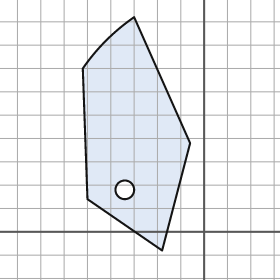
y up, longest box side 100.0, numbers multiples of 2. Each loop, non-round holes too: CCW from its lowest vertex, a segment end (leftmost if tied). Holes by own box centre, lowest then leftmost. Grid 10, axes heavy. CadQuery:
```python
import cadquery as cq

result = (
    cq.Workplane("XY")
    .moveTo(-18.0, -8.0)
    .lineTo(-6.0, 38.0)
    .lineTo(-30.0, 92.0)
    .threePointArc((-42.0, 82.0), (-52.0, 70.0))
    .lineTo(-50.0, 14.0)
    .close()
    .moveTo(-34.0, 18.0)
    .circle(4.0)
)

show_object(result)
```